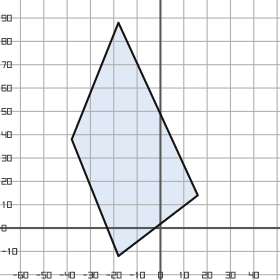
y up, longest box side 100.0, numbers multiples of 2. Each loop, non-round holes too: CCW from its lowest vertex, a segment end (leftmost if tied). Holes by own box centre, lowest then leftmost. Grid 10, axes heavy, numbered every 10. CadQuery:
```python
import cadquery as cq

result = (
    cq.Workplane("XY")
    .moveTo(-18.0, -12.0)
    .lineTo(16.0, 14.0)
    .lineTo(-18.0, 88.0)
    .lineTo(-38.0, 38.0)
    .close()
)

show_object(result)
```